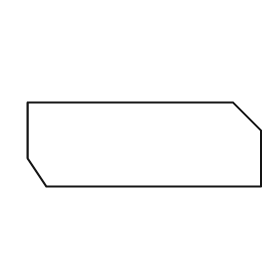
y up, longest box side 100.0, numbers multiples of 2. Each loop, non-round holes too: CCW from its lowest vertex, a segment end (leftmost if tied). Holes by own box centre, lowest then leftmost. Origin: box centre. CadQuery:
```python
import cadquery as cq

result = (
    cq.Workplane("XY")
    .moveTo(-42.0, -18.0)
    .lineTo(50.0, -18.0)
    .lineTo(50.0, 6.0)
    .lineTo(38.0, 18.0)
    .lineTo(-50.0, 18.0)
    .lineTo(-50.0, -6.0)
    .close()
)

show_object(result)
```